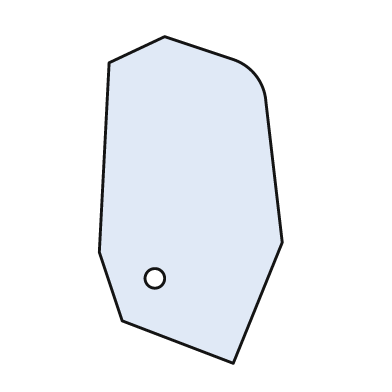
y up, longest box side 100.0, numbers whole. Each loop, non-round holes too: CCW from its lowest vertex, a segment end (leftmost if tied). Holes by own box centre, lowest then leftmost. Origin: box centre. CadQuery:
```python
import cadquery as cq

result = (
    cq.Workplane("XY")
    .moveTo(13.0, -50.0)
    .lineTo(28.0, -13.0)
    .lineTo(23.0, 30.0)
    .threePointArc((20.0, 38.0), (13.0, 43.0))
    .lineTo(-8.0, 50.0)
    .lineTo(-25.0, 42.0)
    .lineTo(-28.0, -16.0)
    .lineTo(-21.0, -37.0)
    .close()
    .moveTo(-11.0, -24.0)
    .circle(3.0)
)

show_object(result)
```